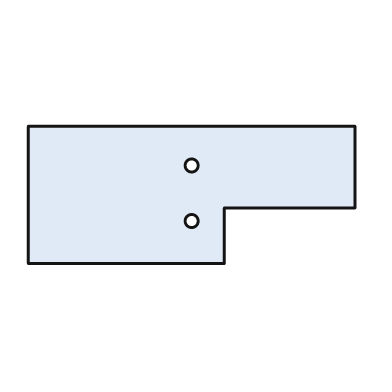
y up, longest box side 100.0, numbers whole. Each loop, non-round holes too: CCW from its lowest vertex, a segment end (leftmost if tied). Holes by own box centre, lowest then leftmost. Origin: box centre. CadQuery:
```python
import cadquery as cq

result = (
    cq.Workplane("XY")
    .moveTo(-50.0, -21.0)
    .lineTo(10.0, -21.0)
    .lineTo(10.0, -4.0)
    .lineTo(50.0, -4.0)
    .lineTo(50.0, 21.0)
    .lineTo(-50.0, 21.0)
    .close()
    .moveTo(0.0, -8.0)
    .circle(2.0)
    .moveTo(0.0, 9.0)
    .circle(2.0)
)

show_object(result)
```